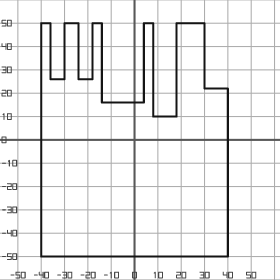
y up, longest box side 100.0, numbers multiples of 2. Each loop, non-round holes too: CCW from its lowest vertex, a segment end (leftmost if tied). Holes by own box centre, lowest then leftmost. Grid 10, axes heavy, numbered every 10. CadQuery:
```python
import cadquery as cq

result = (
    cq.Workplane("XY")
    .moveTo(-40.0, -50.0)
    .lineTo(40.0, -50.0)
    .lineTo(40.0, 22.0)
    .lineTo(30.0, 22.0)
    .lineTo(30.0, 50.0)
    .lineTo(18.0, 50.0)
    .lineTo(18.0, 10.0)
    .lineTo(8.0, 10.0)
    .lineTo(8.0, 50.0)
    .lineTo(4.0, 50.0)
    .lineTo(4.0, 16.0)
    .lineTo(-14.0, 16.0)
    .lineTo(-14.0, 50.0)
    .lineTo(-18.0, 50.0)
    .lineTo(-18.0, 26.0)
    .lineTo(-24.0, 26.0)
    .lineTo(-24.0, 50.0)
    .lineTo(-30.0, 50.0)
    .lineTo(-30.0, 26.0)
    .lineTo(-36.0, 26.0)
    .lineTo(-36.0, 50.0)
    .lineTo(-40.0, 50.0)
    .close()
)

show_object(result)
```